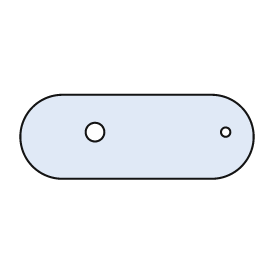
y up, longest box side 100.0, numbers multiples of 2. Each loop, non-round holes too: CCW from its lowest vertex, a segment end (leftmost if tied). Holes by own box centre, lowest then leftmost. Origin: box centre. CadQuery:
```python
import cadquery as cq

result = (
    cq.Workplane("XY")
    .moveTo(-32.0, -18.0)
    .lineTo(32.0, -18.0)
    .threePointArc((50.0, 0.0), (32.0, 18.0))
    .lineTo(-32.0, 18.0)
    .threePointArc((-50.0, 0.0), (-32.0, -18.0))
    .close()
    .moveTo(-18.0, 2.0)
    .circle(4.0)
    .moveTo(38.0, 2.0)
    .circle(2.0)
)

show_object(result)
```